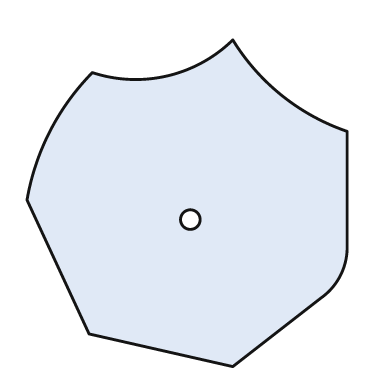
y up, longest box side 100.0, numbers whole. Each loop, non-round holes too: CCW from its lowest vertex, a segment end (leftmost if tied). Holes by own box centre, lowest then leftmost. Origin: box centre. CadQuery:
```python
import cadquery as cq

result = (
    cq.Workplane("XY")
    .moveTo(14.0, -50.0)
    .lineTo(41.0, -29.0)
    .threePointArc((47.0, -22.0), (49.0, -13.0))
    .lineTo(49.0, 22.0)
    .threePointArc((29.0, 33.0), (14.0, 50.0))
    .threePointArc((-6.0, 39.0), (-29.0, 40.0))
    .threePointArc((-42.0, 22.0), (-49.0, 1.0))
    .lineTo(-30.0, -40.0)
    .close()
    .moveTo(1.0, -5.0)
    .circle(3.0)
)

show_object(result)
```